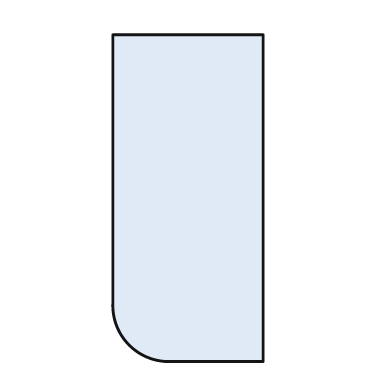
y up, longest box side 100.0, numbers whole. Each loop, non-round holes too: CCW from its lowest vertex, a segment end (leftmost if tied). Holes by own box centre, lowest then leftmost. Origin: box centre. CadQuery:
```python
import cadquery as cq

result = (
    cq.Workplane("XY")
    .moveTo(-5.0, -50.0)
    .lineTo(23.0, -50.0)
    .lineTo(23.0, 50.0)
    .lineTo(-23.0, 50.0)
    .lineTo(-23.0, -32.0)
    .threePointArc((-18.0, -45.0), (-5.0, -50.0))
    .close()
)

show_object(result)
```